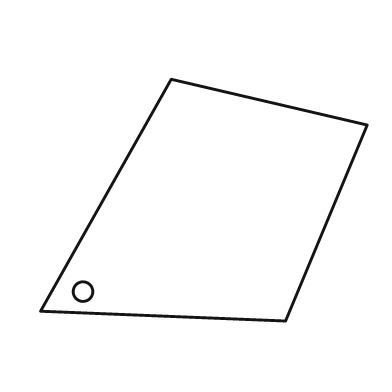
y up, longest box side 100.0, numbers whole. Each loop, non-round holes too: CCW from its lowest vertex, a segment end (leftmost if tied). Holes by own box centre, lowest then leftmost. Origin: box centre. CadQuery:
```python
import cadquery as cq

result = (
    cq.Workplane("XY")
    .moveTo(25.0, -37.0)
    .lineTo(50.0, 23.0)
    .lineTo(-10.0, 37.0)
    .lineTo(-50.0, -34.0)
    .close()
    .moveTo(-37.0, -28.0)
    .circle(3.0)
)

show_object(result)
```